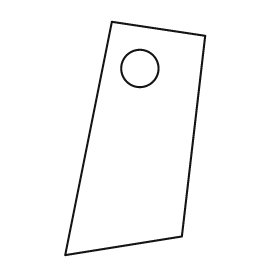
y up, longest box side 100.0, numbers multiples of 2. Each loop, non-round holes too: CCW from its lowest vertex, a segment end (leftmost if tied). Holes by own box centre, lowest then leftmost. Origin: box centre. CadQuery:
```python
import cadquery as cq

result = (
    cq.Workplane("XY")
    .moveTo(-30.0, -50.0)
    .lineTo(20.0, -42.0)
    .lineTo(30.0, 44.0)
    .lineTo(-10.0, 50.0)
    .close()
    .moveTo(2.0, 30.0)
    .circle(8.0)
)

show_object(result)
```